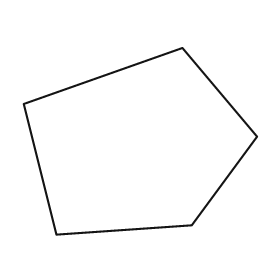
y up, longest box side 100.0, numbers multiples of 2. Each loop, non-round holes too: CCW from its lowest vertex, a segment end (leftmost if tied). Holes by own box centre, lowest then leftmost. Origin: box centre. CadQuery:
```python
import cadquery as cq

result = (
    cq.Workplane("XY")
    .moveTo(-36.0, -40.0)
    .lineTo(22.0, -36.0)
    .lineTo(50.0, 2.0)
    .lineTo(18.0, 40.0)
    .lineTo(-50.0, 16.0)
    .close()
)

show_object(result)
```